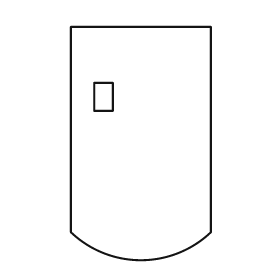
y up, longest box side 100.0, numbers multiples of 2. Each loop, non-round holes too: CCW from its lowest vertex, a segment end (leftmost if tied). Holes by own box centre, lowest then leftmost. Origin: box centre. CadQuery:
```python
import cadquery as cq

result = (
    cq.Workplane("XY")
    .moveTo(-30.0, -38.0)
    .threePointArc((0.0, -50.0), (30.0, -38.0))
    .lineTo(30.0, 50.0)
    .lineTo(-30.0, 50.0)
    .close()
    .moveTo(-20.0, 14.0)
    .lineTo(-12.0, 14.0)
    .lineTo(-12.0, 26.0)
    .lineTo(-20.0, 26.0)
    .close()
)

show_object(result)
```